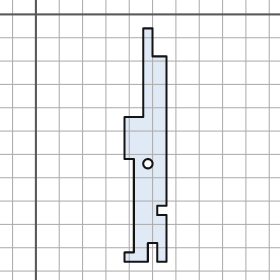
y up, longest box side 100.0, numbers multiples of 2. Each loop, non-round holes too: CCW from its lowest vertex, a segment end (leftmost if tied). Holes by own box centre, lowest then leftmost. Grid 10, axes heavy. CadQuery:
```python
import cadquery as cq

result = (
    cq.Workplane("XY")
    .moveTo(38.0, -106.0)
    .lineTo(48.0, -106.0)
    .lineTo(48.0, -98.0)
    .lineTo(52.0, -98.0)
    .lineTo(52.0, -106.0)
    .lineTo(56.0, -106.0)
    .lineTo(56.0, -86.0)
    .lineTo(52.0, -86.0)
    .lineTo(52.0, -82.0)
    .lineTo(56.0, -82.0)
    .lineTo(56.0, -18.0)
    .lineTo(50.0, -18.0)
    .lineTo(50.0, -6.0)
    .lineTo(46.0, -6.0)
    .lineTo(46.0, -44.0)
    .lineTo(38.0, -44.0)
    .lineTo(38.0, -62.0)
    .lineTo(42.0, -62.0)
    .lineTo(42.0, -102.0)
    .lineTo(38.0, -102.0)
    .close()
    .moveTo(48.0, -64.0)
    .circle(2.0)
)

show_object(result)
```